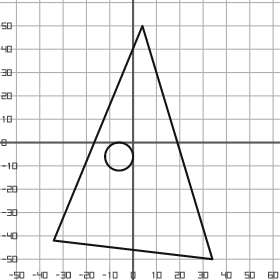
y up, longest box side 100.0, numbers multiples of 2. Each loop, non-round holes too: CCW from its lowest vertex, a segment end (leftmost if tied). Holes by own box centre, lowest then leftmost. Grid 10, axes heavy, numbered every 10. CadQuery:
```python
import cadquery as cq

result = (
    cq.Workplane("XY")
    .moveTo(34.0, -50.0)
    .lineTo(4.0, 50.0)
    .lineTo(-34.0, -42.0)
    .close()
    .moveTo(-6.0, -6.0)
    .circle(6.0)
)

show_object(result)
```